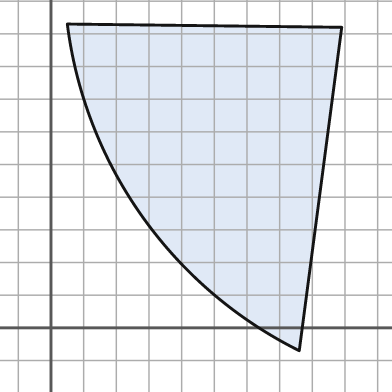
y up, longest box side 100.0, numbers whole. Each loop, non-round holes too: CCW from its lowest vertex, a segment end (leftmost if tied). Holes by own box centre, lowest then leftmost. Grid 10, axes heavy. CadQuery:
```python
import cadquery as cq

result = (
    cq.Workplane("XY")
    .moveTo(76.0, -7.0)
    .lineTo(89.0, 92.0)
    .lineTo(5.0, 93.0)
    .threePointArc((28.0, 34.0), (76.0, -7.0))
    .close()
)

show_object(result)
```